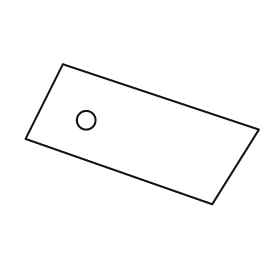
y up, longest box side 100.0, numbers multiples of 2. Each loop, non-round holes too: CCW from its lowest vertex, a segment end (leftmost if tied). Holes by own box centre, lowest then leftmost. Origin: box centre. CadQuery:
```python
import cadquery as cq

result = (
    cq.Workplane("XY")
    .moveTo(30.0, -30.0)
    .lineTo(50.0, 2.0)
    .lineTo(-34.0, 30.0)
    .lineTo(-50.0, -2.0)
    .close()
    .moveTo(-24.0, 6.0)
    .circle(4.0)
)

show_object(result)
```